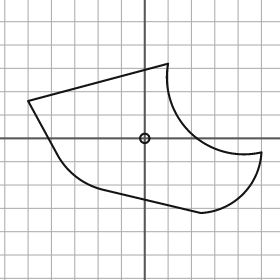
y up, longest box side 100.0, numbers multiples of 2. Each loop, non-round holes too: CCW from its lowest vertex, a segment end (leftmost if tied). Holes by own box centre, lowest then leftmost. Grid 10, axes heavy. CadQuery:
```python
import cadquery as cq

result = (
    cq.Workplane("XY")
    .moveTo(24.0, -32.0)
    .threePointArc((42.0, -24.0), (50.0, -6.0))
    .threePointArc((20.0, 2.0), (10.0, 32.0))
    .lineTo(-50.0, 16.0)
    .lineTo(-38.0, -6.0)
    .threePointArc((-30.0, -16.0), (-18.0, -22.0))
    .close()
    .moveTo(0.0, 0.0)
    .circle(2.0)
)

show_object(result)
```